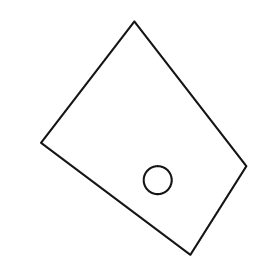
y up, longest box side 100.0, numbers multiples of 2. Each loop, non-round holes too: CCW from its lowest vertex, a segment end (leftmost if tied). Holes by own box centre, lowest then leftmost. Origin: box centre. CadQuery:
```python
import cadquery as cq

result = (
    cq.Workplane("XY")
    .moveTo(20.0, -50.0)
    .lineTo(44.0, -12.0)
    .lineTo(-4.0, 50.0)
    .lineTo(-44.0, -2.0)
    .close()
    .moveTo(6.0, -18.0)
    .circle(6.0)
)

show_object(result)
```